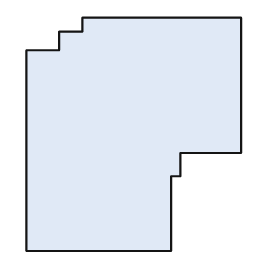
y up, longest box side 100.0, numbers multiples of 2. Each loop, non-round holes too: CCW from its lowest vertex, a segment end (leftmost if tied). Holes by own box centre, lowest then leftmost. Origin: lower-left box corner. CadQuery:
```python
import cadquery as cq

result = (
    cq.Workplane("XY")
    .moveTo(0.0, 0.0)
    .lineTo(62.0, 0.0)
    .lineTo(62.0, 32.0)
    .lineTo(66.0, 32.0)
    .lineTo(66.0, 42.0)
    .lineTo(92.0, 42.0)
    .lineTo(92.0, 100.0)
    .lineTo(24.0, 100.0)
    .lineTo(24.0, 94.0)
    .lineTo(14.0, 94.0)
    .lineTo(14.0, 86.0)
    .lineTo(0.0, 86.0)
    .close()
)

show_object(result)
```